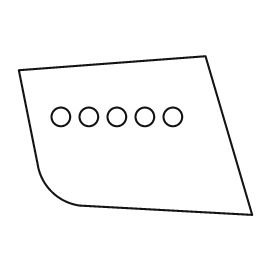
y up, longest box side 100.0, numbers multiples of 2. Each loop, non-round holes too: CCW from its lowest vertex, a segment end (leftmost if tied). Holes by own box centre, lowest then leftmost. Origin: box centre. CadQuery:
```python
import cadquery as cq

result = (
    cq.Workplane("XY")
    .moveTo(50.0, -34.0)
    .lineTo(30.0, 34.0)
    .lineTo(-50.0, 28.0)
    .lineTo(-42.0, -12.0)
    .threePointArc((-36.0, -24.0), (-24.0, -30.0))
    .close()
    .moveTo(-32.0, 8.0)
    .circle(4.0)
    .moveTo(-20.0, 8.0)
    .circle(4.0)
    .moveTo(-8.0, 8.0)
    .circle(4.0)
    .moveTo(4.0, 8.0)
    .circle(4.0)
    .moveTo(16.0, 8.0)
    .circle(4.0)
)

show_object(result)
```